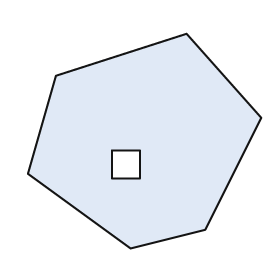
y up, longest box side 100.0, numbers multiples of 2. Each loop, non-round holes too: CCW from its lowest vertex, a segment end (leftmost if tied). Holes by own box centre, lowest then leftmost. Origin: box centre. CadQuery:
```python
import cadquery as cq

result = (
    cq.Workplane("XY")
    .moveTo(-6.0, -46.0)
    .lineTo(26.0, -38.0)
    .lineTo(50.0, 10.0)
    .lineTo(18.0, 46.0)
    .lineTo(-38.0, 28.0)
    .lineTo(-50.0, -14.0)
    .close()
    .moveTo(-14.0, -16.0)
    .lineTo(-2.0, -16.0)
    .lineTo(-2.0, -4.0)
    .lineTo(-14.0, -4.0)
    .close()
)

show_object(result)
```